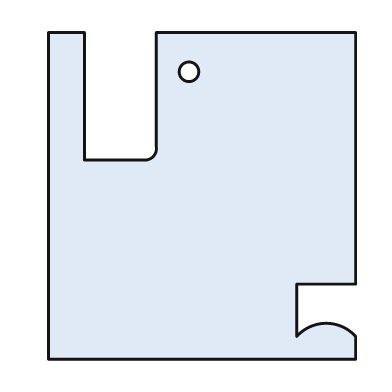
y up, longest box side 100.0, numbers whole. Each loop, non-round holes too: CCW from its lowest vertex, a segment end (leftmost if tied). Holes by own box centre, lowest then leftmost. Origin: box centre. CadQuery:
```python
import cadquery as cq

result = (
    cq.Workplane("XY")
    .moveTo(-47.0, -50.0)
    .lineTo(47.0, -50.0)
    .lineTo(47.0, -43.0)
    .threePointArc((38.0, -39.0), (29.0, -43.0))
    .lineTo(29.0, -27.0)
    .lineTo(47.0, -27.0)
    .lineTo(47.0, 50.0)
    .lineTo(-14.0, 50.0)
    .lineTo(-14.0, 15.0)
    .threePointArc((-15.0, 12.0), (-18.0, 11.0))
    .lineTo(-36.0, 11.0)
    .lineTo(-36.0, 50.0)
    .lineTo(-47.0, 50.0)
    .close()
    .moveTo(-4.0, 38.0)
    .circle(3.0)
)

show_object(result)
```